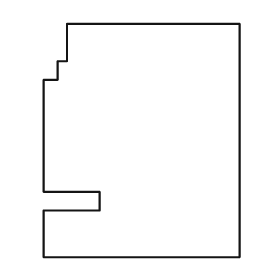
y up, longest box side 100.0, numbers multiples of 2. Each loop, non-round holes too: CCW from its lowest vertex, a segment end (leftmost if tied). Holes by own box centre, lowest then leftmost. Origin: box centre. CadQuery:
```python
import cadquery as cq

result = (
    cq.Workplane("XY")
    .moveTo(-42.0, -50.0)
    .lineTo(42.0, -50.0)
    .lineTo(42.0, 50.0)
    .lineTo(-32.0, 50.0)
    .lineTo(-32.0, 34.0)
    .lineTo(-36.0, 34.0)
    .lineTo(-36.0, 26.0)
    .lineTo(-42.0, 26.0)
    .lineTo(-42.0, -22.0)
    .lineTo(-18.0, -22.0)
    .lineTo(-18.0, -30.0)
    .lineTo(-42.0, -30.0)
    .close()
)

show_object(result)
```